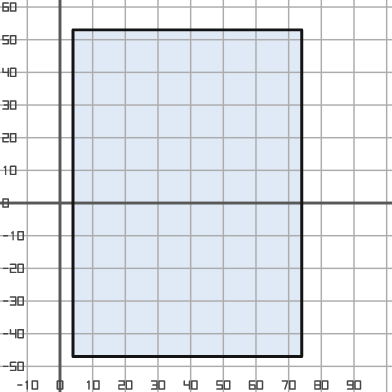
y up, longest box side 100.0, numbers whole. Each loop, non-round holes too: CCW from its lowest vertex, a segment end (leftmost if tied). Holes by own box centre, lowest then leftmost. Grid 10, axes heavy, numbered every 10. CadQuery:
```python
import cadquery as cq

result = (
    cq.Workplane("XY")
    .moveTo(4.0, -47.0)
    .lineTo(74.0, -47.0)
    .lineTo(74.0, 53.0)
    .lineTo(4.0, 53.0)
    .close()
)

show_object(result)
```